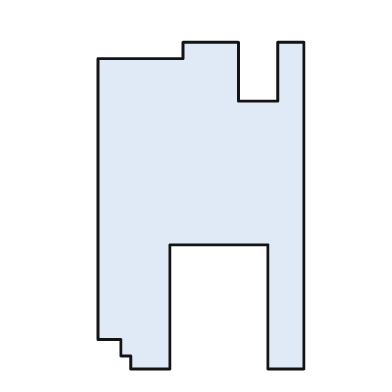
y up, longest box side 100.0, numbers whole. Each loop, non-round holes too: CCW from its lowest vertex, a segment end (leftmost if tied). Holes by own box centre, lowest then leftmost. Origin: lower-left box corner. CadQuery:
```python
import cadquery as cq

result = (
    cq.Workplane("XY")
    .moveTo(10.0, 0.0)
    .lineTo(22.0, 0.0)
    .lineTo(22.0, 38.0)
    .lineTo(52.0, 38.0)
    .lineTo(52.0, 0.0)
    .lineTo(63.0, 0.0)
    .lineTo(63.0, 100.0)
    .lineTo(55.0, 100.0)
    .lineTo(55.0, 82.0)
    .lineTo(43.0, 82.0)
    .lineTo(43.0, 100.0)
    .lineTo(26.0, 100.0)
    .lineTo(26.0, 95.0)
    .lineTo(0.0, 95.0)
    .lineTo(0.0, 9.0)
    .lineTo(7.0, 9.0)
    .lineTo(7.0, 4.0)
    .lineTo(10.0, 4.0)
    .close()
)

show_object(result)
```